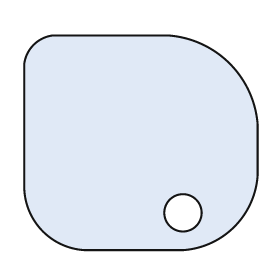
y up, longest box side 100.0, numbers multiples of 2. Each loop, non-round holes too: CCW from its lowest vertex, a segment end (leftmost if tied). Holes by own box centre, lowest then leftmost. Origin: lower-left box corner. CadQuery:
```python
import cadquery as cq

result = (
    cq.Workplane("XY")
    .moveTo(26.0, 0.0)
    .lineTo(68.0, 0.0)
    .threePointArc((90.0, 10.0), (100.0, 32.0))
    .lineTo(100.0, 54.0)
    .threePointArc((88.0, 80.0), (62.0, 92.0))
    .lineTo(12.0, 92.0)
    .threePointArc((4.0, 88.0), (0.0, 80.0))
    .lineTo(0.0, 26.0)
    .threePointArc((8.0, 8.0), (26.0, 0.0))
    .close()
    .moveTo(68.0, 16.0)
    .circle(8.0)
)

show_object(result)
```